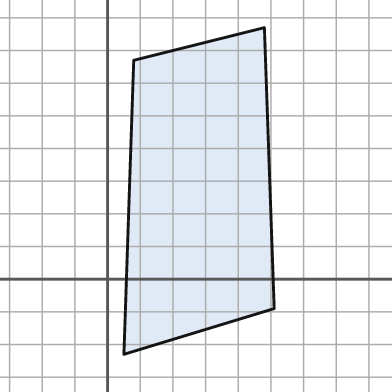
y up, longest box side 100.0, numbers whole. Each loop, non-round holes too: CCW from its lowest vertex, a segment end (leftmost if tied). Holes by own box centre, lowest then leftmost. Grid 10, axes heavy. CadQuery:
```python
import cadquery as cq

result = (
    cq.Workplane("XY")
    .moveTo(5.0, -23.0)
    .lineTo(51.0, -9.0)
    .lineTo(48.0, 77.0)
    .lineTo(8.0, 67.0)
    .close()
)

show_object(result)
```